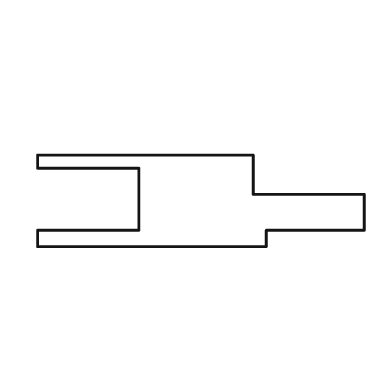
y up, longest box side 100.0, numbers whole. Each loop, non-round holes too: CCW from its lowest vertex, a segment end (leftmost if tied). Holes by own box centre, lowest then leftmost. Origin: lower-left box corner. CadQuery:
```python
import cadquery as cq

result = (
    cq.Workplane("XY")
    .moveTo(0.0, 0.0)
    .lineTo(70.0, 0.0)
    .lineTo(70.0, 5.0)
    .lineTo(100.0, 5.0)
    .lineTo(100.0, 16.0)
    .lineTo(66.0, 16.0)
    .lineTo(66.0, 28.0)
    .lineTo(0.0, 28.0)
    .lineTo(0.0, 24.0)
    .lineTo(31.0, 24.0)
    .lineTo(31.0, 5.0)
    .lineTo(0.0, 5.0)
    .close()
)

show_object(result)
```